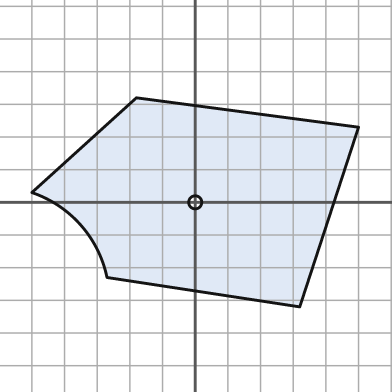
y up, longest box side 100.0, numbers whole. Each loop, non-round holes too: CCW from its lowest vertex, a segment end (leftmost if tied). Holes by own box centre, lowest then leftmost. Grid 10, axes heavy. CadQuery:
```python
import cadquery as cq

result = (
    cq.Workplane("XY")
    .moveTo(32.0, -32.0)
    .lineTo(50.0, 23.0)
    .lineTo(-18.0, 32.0)
    .lineTo(-50.0, 3.0)
    .threePointArc((-35.0, -7.0), (-27.0, -23.0))
    .close()
    .moveTo(0.0, 0.0)
    .circle(2.0)
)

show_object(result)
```